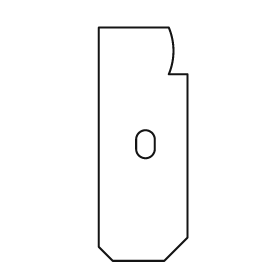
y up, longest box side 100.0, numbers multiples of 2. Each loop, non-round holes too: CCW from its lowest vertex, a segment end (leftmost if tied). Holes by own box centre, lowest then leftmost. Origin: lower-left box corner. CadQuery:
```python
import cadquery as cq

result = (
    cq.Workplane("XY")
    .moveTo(6.0, 0.0)
    .lineTo(28.0, 0.0)
    .lineTo(38.0, 10.0)
    .lineTo(38.0, 80.0)
    .lineTo(30.0, 80.0)
    .threePointArc((32.0, 90.0), (30.0, 100.0))
    .lineTo(0.0, 100.0)
    .lineTo(0.0, 6.0)
    .close()
    .moveTo(16.0, 48.0)
    .threePointArc((20.0, 44.0), (24.0, 48.0))
    .lineTo(24.0, 52.0)
    .threePointArc((20.0, 56.0), (16.0, 52.0))
    .close()
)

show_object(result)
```